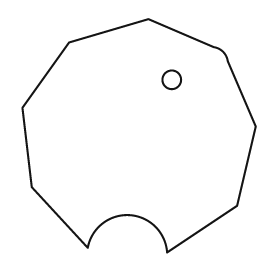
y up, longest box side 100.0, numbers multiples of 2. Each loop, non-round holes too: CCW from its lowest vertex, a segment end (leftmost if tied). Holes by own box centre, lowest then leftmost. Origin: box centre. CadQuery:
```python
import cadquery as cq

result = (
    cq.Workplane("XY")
    .moveTo(12.0, -50.0)
    .lineTo(42.0, -30.0)
    .lineTo(50.0, 4.0)
    .lineTo(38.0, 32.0)
    .threePointArc((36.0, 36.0), (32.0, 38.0))
    .lineTo(4.0, 50.0)
    .lineTo(-30.0, 40.0)
    .lineTo(-50.0, 12.0)
    .lineTo(-46.0, -22.0)
    .lineTo(-22.0, -48.0)
    .threePointArc((-4.0, -34.0), (12.0, -50.0))
    .close()
    .moveTo(14.0, 24.0)
    .circle(4.0)
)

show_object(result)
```